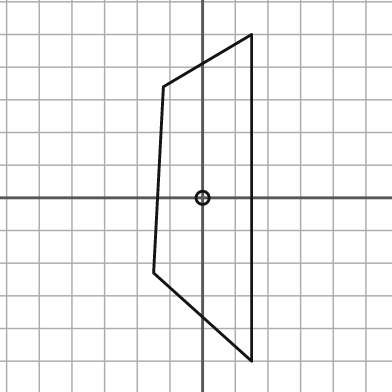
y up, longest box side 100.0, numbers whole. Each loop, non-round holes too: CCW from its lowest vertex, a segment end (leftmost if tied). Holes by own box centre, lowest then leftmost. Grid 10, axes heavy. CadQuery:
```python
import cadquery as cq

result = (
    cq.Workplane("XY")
    .moveTo(15.0, -50.0)
    .lineTo(15.0, 50.0)
    .lineTo(-12.0, 34.0)
    .lineTo(-15.0, -23.0)
    .close()
    .moveTo(0.0, 0.0)
    .circle(2.0)
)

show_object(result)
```